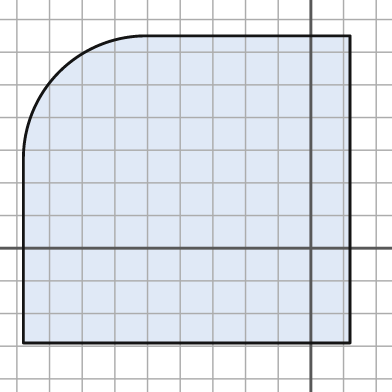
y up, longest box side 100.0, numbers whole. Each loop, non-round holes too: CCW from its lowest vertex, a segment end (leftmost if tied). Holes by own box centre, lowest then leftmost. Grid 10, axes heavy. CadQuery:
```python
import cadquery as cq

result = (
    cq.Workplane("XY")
    .moveTo(-88.0, -29.0)
    .lineTo(12.0, -29.0)
    .lineTo(12.0, 65.0)
    .lineTo(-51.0, 65.0)
    .threePointArc((-77.0, 54.0), (-88.0, 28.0))
    .close()
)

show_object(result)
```